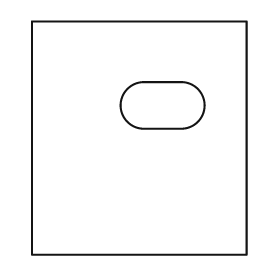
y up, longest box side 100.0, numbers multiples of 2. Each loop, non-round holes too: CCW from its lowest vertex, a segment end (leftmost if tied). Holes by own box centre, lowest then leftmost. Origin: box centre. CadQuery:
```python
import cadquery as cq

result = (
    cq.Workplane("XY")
    .moveTo(-46.0, -50.0)
    .lineTo(46.0, -50.0)
    .lineTo(46.0, 50.0)
    .lineTo(-46.0, 50.0)
    .close()
    .moveTo(2.0, 4.0)
    .lineTo(18.0, 4.0)
    .threePointArc((28.0, 14.0), (18.0, 24.0))
    .lineTo(2.0, 24.0)
    .threePointArc((-8.0, 14.0), (2.0, 4.0))
    .close()
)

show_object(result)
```